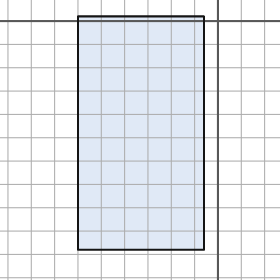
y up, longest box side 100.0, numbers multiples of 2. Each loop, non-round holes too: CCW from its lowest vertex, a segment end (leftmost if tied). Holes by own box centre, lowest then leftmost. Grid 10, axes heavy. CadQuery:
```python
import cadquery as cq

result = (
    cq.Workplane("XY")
    .moveTo(-60.0, -98.0)
    .lineTo(-6.0, -98.0)
    .lineTo(-6.0, 2.0)
    .lineTo(-60.0, 2.0)
    .close()
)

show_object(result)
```